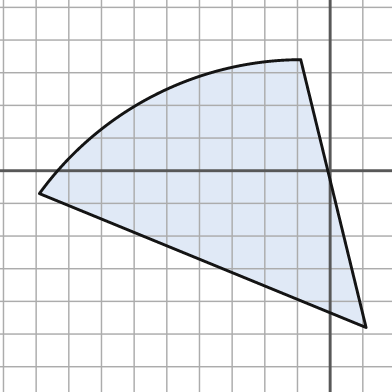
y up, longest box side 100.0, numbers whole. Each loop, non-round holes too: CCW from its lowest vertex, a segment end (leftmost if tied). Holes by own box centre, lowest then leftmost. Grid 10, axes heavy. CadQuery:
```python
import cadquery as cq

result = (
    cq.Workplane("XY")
    .moveTo(11.0, -48.0)
    .lineTo(-9.0, 34.0)
    .threePointArc((-54.0, 23.0), (-89.0, -7.0))
    .close()
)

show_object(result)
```